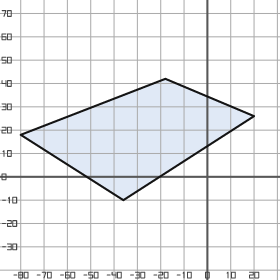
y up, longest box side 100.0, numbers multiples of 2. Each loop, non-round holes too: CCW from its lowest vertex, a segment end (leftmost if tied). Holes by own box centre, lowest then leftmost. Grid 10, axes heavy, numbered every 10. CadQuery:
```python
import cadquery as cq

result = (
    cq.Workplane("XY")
    .moveTo(-36.0, -10.0)
    .lineTo(20.0, 26.0)
    .lineTo(-18.0, 42.0)
    .lineTo(-80.0, 18.0)
    .close()
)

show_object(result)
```